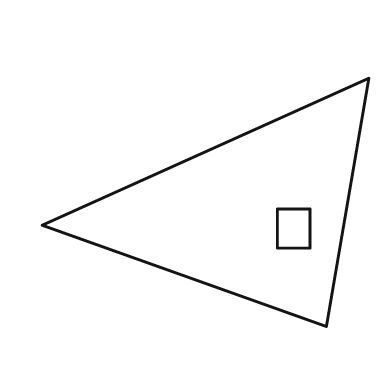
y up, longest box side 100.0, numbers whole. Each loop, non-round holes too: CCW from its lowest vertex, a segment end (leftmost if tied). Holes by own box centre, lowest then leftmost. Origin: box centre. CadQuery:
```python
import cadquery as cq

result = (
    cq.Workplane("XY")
    .moveTo(37.0, -38.0)
    .lineTo(50.0, 38.0)
    .lineTo(-50.0, -7.0)
    .close()
    .moveTo(22.0, -14.0)
    .lineTo(32.0, -14.0)
    .lineTo(32.0, -2.0)
    .lineTo(22.0, -2.0)
    .close()
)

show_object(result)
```